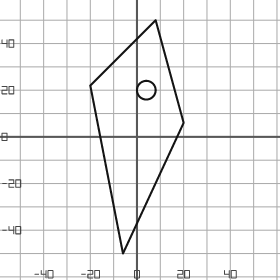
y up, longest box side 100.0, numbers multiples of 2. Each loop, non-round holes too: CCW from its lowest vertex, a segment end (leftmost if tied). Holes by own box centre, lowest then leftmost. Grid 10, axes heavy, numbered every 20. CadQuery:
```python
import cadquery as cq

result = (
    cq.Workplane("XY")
    .moveTo(-6.0, -50.0)
    .lineTo(20.0, 6.0)
    .lineTo(8.0, 50.0)
    .lineTo(-20.0, 22.0)
    .close()
    .moveTo(4.0, 20.0)
    .circle(4.0)
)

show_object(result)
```